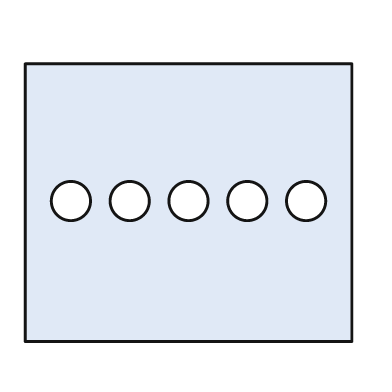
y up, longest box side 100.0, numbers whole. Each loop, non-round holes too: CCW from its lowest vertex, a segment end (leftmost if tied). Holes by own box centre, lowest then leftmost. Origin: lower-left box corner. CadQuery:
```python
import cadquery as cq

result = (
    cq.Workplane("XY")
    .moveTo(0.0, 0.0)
    .lineTo(100.0, 0.0)
    .lineTo(100.0, 85.0)
    .lineTo(0.0, 85.0)
    .close()
    .moveTo(14.0, 43.0)
    .circle(6.0)
    .moveTo(32.0, 43.0)
    .circle(6.0)
    .moveTo(50.0, 43.0)
    .circle(6.0)
    .moveTo(68.0, 43.0)
    .circle(6.0)
    .moveTo(86.0, 43.0)
    .circle(6.0)
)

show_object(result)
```